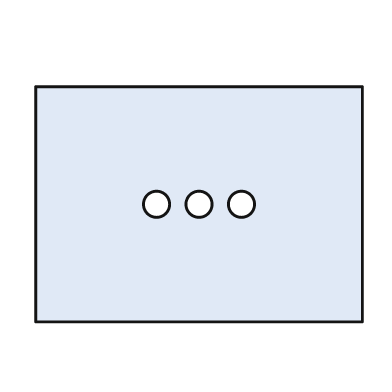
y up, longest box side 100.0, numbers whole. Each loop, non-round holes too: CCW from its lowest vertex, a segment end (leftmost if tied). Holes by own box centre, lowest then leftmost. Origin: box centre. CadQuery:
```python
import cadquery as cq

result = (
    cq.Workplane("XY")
    .moveTo(-50.0, -36.0)
    .lineTo(50.0, -36.0)
    .lineTo(50.0, 36.0)
    .lineTo(-50.0, 36.0)
    .close()
    .moveTo(-13.0, 0.0)
    .circle(4.0)
    .moveTo(0.0, 0.0)
    .circle(4.0)
    .moveTo(13.0, 0.0)
    .circle(4.0)
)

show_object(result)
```